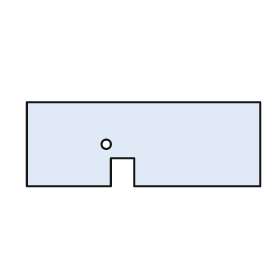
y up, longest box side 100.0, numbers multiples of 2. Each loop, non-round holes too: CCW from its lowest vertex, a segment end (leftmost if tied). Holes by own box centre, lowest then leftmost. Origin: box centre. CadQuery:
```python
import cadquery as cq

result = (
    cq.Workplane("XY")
    .moveTo(-50.0, -18.0)
    .lineTo(-14.0, -18.0)
    .lineTo(-14.0, -6.0)
    .lineTo(-4.0, -6.0)
    .lineTo(-4.0, -18.0)
    .lineTo(50.0, -18.0)
    .lineTo(50.0, 18.0)
    .lineTo(-50.0, 18.0)
    .close()
    .moveTo(-16.0, 0.0)
    .circle(2.0)
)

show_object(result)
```